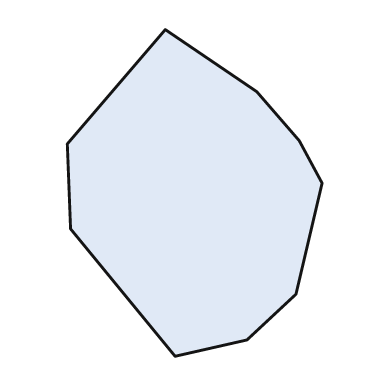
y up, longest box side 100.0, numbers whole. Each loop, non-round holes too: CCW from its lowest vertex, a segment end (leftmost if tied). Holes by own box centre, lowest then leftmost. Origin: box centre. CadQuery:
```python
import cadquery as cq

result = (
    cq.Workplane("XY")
    .moveTo(-6.0, -50.0)
    .lineTo(16.0, -45.0)
    .lineTo(31.0, -31.0)
    .lineTo(39.0, 3.0)
    .lineTo(32.0, 16.0)
    .lineTo(19.0, 31.0)
    .lineTo(-9.0, 50.0)
    .lineTo(-39.0, 15.0)
    .lineTo(-38.0, -11.0)
    .close()
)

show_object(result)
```